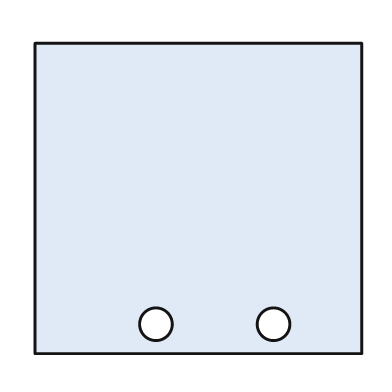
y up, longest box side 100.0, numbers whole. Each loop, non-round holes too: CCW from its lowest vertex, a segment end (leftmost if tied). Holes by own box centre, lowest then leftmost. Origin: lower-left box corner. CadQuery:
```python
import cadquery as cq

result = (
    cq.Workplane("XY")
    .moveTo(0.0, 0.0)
    .lineTo(100.0, 0.0)
    .lineTo(100.0, 95.0)
    .lineTo(0.0, 95.0)
    .close()
    .moveTo(37.0, 9.0)
    .circle(5.0)
    .moveTo(73.0, 9.0)
    .circle(5.0)
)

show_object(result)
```